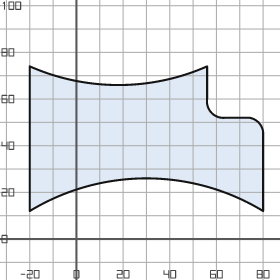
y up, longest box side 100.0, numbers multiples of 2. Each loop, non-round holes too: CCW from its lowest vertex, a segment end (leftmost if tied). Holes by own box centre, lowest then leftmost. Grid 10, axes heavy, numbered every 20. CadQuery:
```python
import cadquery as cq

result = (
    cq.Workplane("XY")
    .moveTo(-20.0, 12.0)
    .threePointArc((30.0, 26.0), (80.0, 12.0))
    .lineTo(80.0, 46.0)
    .threePointArc((78.0, 50.0), (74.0, 52.0))
    .lineTo(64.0, 52.0)
    .threePointArc((58.0, 54.0), (56.0, 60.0))
    .lineTo(56.0, 74.0)
    .threePointArc((18.0, 66.0), (-20.0, 74.0))
    .close()
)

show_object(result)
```